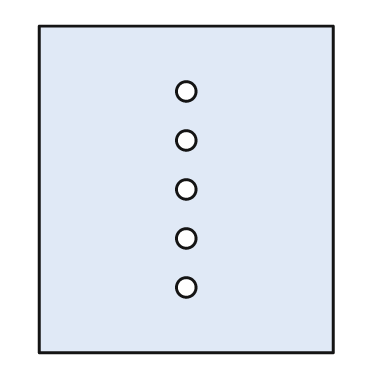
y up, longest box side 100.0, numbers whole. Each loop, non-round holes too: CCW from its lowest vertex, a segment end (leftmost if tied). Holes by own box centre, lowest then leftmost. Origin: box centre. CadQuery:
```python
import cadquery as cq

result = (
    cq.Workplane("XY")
    .moveTo(-45.0, -50.0)
    .lineTo(45.0, -50.0)
    .lineTo(45.0, 50.0)
    .lineTo(-45.0, 50.0)
    .close()
    .moveTo(0.0, -30.0)
    .circle(3.0)
    .moveTo(0.0, -15.0)
    .circle(3.0)
    .moveTo(0.0, 0.0)
    .circle(3.0)
    .moveTo(0.0, 15.0)
    .circle(3.0)
    .moveTo(0.0, 30.0)
    .circle(3.0)
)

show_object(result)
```